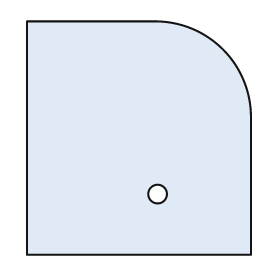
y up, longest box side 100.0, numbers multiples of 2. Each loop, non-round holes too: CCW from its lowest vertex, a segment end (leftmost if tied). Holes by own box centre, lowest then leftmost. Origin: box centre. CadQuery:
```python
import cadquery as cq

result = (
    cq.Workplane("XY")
    .moveTo(-48.0, -50.0)
    .lineTo(48.0, -50.0)
    .lineTo(48.0, 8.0)
    .threePointArc((36.0, 38.0), (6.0, 50.0))
    .lineTo(-48.0, 50.0)
    .close()
    .moveTo(8.0, -24.0)
    .circle(4.0)
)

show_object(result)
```